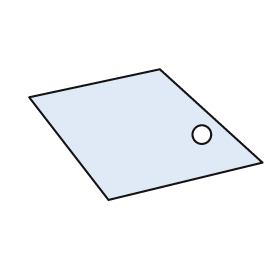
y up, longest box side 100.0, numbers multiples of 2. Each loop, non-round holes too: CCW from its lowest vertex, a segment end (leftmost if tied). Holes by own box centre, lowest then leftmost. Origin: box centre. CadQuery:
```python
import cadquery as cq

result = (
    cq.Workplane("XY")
    .moveTo(-16.0, -28.0)
    .lineTo(50.0, -12.0)
    .lineTo(6.0, 28.0)
    .lineTo(-50.0, 16.0)
    .close()
    .moveTo(24.0, 0.0)
    .circle(4.0)
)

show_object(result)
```